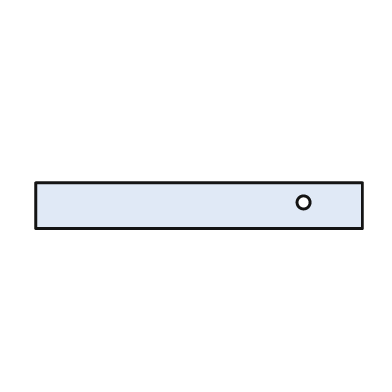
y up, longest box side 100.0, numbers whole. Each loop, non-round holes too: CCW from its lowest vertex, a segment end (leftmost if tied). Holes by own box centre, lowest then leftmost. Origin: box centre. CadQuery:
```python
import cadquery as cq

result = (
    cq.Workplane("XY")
    .moveTo(-50.0, -7.0)
    .lineTo(50.0, -7.0)
    .lineTo(50.0, 7.0)
    .lineTo(-50.0, 7.0)
    .close()
    .moveTo(32.0, 1.0)
    .circle(2.0)
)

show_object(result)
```